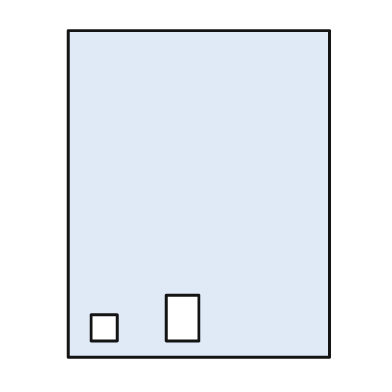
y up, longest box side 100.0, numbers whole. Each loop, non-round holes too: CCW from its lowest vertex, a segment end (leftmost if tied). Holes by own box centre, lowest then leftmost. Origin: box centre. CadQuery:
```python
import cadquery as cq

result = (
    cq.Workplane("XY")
    .moveTo(-40.0, -50.0)
    .lineTo(40.0, -50.0)
    .lineTo(40.0, 50.0)
    .lineTo(-40.0, 50.0)
    .close()
    .moveTo(-33.0, -45.0)
    .lineTo(-25.0, -45.0)
    .lineTo(-25.0, -37.0)
    .lineTo(-33.0, -37.0)
    .close()
    .moveTo(-10.0, -45.0)
    .lineTo(0.0, -45.0)
    .lineTo(0.0, -31.0)
    .lineTo(-10.0, -31.0)
    .close()
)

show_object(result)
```